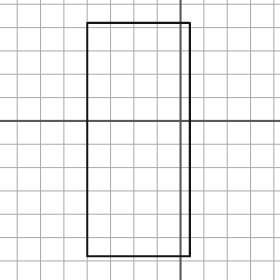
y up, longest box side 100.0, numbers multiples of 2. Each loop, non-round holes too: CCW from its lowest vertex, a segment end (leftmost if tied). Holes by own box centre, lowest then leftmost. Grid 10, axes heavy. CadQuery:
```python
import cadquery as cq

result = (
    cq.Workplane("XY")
    .moveTo(-40.0, -58.0)
    .lineTo(4.0, -58.0)
    .lineTo(4.0, 42.0)
    .lineTo(-40.0, 42.0)
    .close()
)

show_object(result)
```